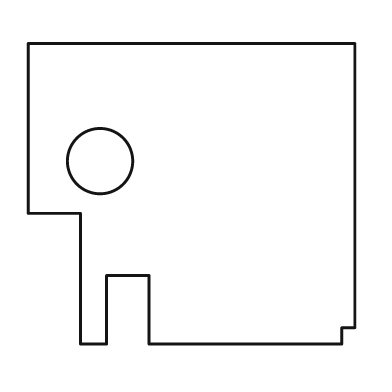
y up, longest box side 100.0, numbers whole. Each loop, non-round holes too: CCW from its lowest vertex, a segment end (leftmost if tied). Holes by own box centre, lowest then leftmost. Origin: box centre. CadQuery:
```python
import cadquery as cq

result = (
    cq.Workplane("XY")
    .moveTo(-34.0, -46.0)
    .lineTo(-26.0, -46.0)
    .lineTo(-26.0, -25.0)
    .lineTo(-13.0, -25.0)
    .lineTo(-13.0, -46.0)
    .lineTo(46.0, -46.0)
    .lineTo(46.0, -41.0)
    .lineTo(50.0, -41.0)
    .lineTo(50.0, 46.0)
    .lineTo(-50.0, 46.0)
    .lineTo(-50.0, -6.0)
    .lineTo(-34.0, -6.0)
    .close()
    .moveTo(-28.0, 10.0)
    .circle(10.0)
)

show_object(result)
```